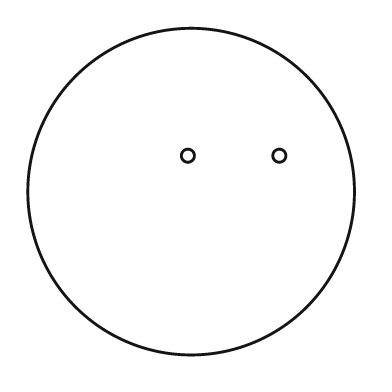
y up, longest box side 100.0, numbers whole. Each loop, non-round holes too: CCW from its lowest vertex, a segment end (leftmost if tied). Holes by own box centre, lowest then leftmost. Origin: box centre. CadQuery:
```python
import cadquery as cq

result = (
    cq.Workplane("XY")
    .moveTo(0.0, 0.0)
    .circle(50.0)
    .moveTo(-1.0, 11.0)
    .circle(2.0)
    .moveTo(27.0, 11.0)
    .circle(2.0)
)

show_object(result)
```